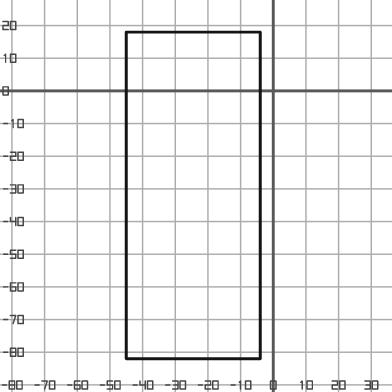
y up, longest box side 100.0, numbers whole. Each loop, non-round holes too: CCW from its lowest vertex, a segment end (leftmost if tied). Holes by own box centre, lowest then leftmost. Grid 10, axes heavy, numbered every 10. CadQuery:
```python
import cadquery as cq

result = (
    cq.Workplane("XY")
    .moveTo(-45.0, -82.0)
    .lineTo(-4.0, -82.0)
    .lineTo(-4.0, 18.0)
    .lineTo(-45.0, 18.0)
    .close()
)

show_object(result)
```